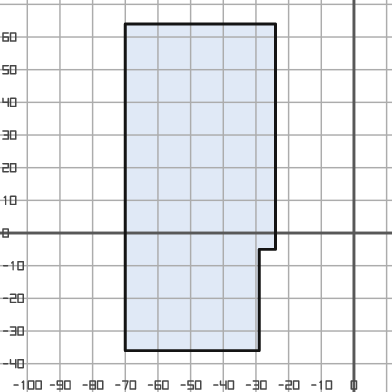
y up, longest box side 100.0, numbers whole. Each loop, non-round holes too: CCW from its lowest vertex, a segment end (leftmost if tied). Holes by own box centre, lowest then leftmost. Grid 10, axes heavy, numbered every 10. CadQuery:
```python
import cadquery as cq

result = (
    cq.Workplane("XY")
    .moveTo(-70.0, -36.0)
    .lineTo(-29.0, -36.0)
    .lineTo(-29.0, -5.0)
    .lineTo(-24.0, -5.0)
    .lineTo(-24.0, 64.0)
    .lineTo(-70.0, 64.0)
    .close()
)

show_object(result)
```